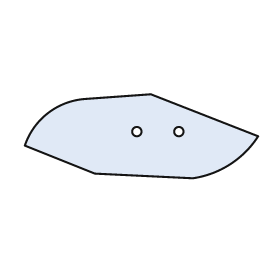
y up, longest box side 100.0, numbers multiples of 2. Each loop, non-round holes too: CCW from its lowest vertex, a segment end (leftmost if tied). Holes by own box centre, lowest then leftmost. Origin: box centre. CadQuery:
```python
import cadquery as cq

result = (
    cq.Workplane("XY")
    .moveTo(22.0, -18.0)
    .threePointArc((38.0, -12.0), (50.0, 0.0))
    .lineTo(4.0, 18.0)
    .lineTo(-24.0, 16.0)
    .threePointArc((-40.0, 10.0), (-50.0, -4.0))
    .lineTo(-20.0, -16.0)
    .close()
    .moveTo(-2.0, 2.0)
    .circle(2.0)
    .moveTo(16.0, 2.0)
    .circle(2.0)
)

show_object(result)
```